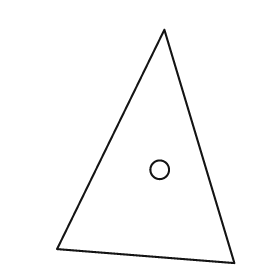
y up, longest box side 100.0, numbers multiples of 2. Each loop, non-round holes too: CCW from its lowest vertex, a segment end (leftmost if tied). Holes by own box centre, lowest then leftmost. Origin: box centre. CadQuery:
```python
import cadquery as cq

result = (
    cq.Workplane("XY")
    .moveTo(38.0, -50.0)
    .lineTo(8.0, 50.0)
    .lineTo(-38.0, -44.0)
    .close()
    .moveTo(6.0, -10.0)
    .circle(4.0)
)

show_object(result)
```